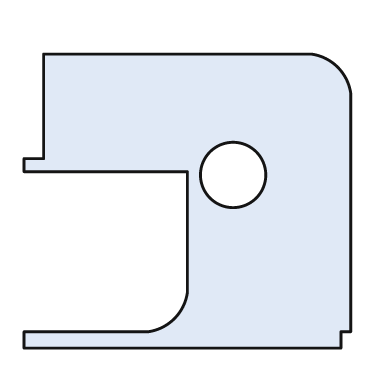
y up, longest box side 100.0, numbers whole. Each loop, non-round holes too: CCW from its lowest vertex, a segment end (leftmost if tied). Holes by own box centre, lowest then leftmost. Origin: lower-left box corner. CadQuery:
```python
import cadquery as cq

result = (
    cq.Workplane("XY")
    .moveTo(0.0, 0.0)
    .lineTo(97.0, 0.0)
    .lineTo(97.0, 5.0)
    .lineTo(100.0, 5.0)
    .lineTo(100.0, 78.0)
    .threePointArc((96.0, 86.0), (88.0, 90.0))
    .lineTo(6.0, 90.0)
    .lineTo(6.0, 58.0)
    .lineTo(0.0, 58.0)
    .lineTo(0.0, 54.0)
    .lineTo(50.0, 54.0)
    .lineTo(50.0, 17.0)
    .threePointArc((46.0, 9.0), (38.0, 5.0))
    .lineTo(0.0, 5.0)
    .close()
    .moveTo(64.0, 53.0)
    .circle(10.0)
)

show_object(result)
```